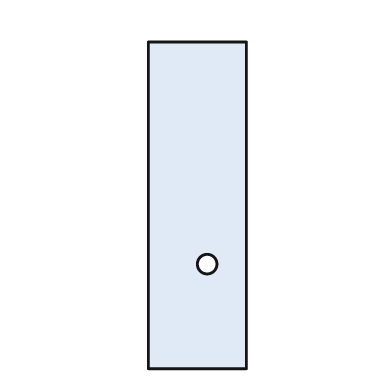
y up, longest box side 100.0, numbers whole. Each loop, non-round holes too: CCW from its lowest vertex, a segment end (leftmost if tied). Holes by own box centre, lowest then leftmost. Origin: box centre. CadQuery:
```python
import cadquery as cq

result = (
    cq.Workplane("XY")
    .moveTo(-15.0, -50.0)
    .lineTo(15.0, -50.0)
    .lineTo(15.0, 50.0)
    .lineTo(-15.0, 50.0)
    .close()
    .moveTo(3.0, -18.0)
    .circle(3.0)
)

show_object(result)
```